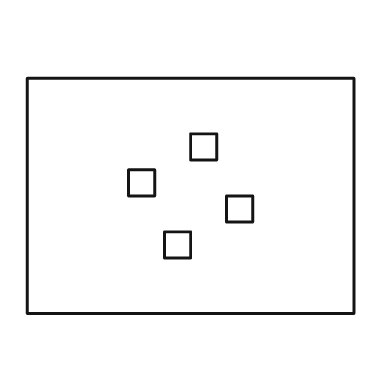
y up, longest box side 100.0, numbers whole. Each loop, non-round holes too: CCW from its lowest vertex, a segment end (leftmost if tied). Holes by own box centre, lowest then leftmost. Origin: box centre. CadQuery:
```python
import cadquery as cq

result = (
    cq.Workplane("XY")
    .moveTo(-50.0, -36.0)
    .lineTo(50.0, -36.0)
    .lineTo(50.0, 36.0)
    .lineTo(-50.0, 36.0)
    .close()
    .moveTo(-8.0, -19.0)
    .lineTo(0.0, -19.0)
    .lineTo(0.0, -11.0)
    .lineTo(-8.0, -11.0)
    .close()
    .moveTo(11.0, -8.0)
    .lineTo(19.0, -8.0)
    .lineTo(19.0, 0.0)
    .lineTo(11.0, 0.0)
    .close()
    .moveTo(-19.0, 0.0)
    .lineTo(-11.0, 0.0)
    .lineTo(-11.0, 8.0)
    .lineTo(-19.0, 8.0)
    .close()
    .moveTo(0.0, 11.0)
    .lineTo(8.0, 11.0)
    .lineTo(8.0, 19.0)
    .lineTo(0.0, 19.0)
    .close()
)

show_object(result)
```